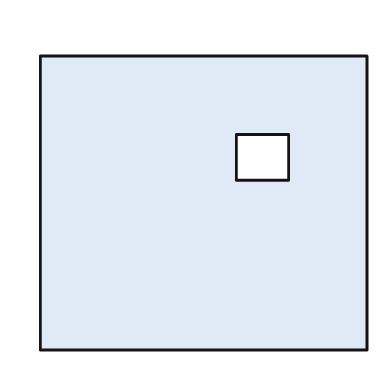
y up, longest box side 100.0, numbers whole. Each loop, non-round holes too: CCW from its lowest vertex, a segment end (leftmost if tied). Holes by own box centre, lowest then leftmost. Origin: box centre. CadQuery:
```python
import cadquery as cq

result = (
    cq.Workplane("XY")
    .moveTo(-50.0, -45.0)
    .lineTo(50.0, -45.0)
    .lineTo(50.0, 45.0)
    .lineTo(-50.0, 45.0)
    .close()
    .moveTo(10.0, 7.0)
    .lineTo(26.0, 7.0)
    .lineTo(26.0, 21.0)
    .lineTo(10.0, 21.0)
    .close()
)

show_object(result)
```